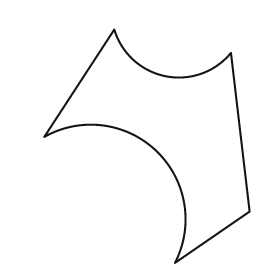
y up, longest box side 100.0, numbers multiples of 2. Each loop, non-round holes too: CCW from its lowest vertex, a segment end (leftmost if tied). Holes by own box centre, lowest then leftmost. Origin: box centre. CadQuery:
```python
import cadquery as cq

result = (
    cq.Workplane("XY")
    .moveTo(12.0, -50.0)
    .lineTo(44.0, -28.0)
    .lineTo(36.0, 40.0)
    .threePointArc((8.0, 30.0), (-14.0, 50.0))
    .lineTo(-44.0, 4.0)
    .threePointArc((4.0, -2.0), (12.0, -50.0))
    .close()
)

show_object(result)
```